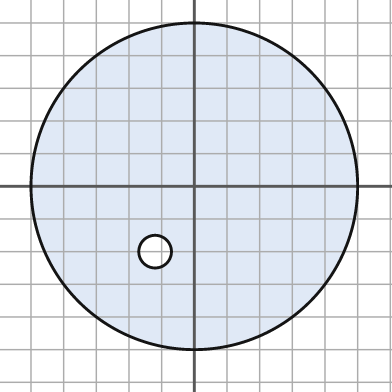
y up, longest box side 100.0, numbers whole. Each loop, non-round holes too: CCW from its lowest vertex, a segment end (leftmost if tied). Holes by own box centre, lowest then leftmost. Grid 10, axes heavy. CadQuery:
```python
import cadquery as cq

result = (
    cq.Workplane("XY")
    .moveTo(0.0, 0.0)
    .circle(50.0)
    .moveTo(-12.0, -20.0)
    .circle(5.0)
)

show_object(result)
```